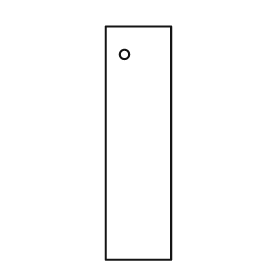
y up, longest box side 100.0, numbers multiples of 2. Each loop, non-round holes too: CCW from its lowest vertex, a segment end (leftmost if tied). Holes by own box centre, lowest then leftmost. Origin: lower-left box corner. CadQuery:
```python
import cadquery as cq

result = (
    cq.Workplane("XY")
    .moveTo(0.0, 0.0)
    .lineTo(28.0, 0.0)
    .lineTo(28.0, 100.0)
    .lineTo(0.0, 100.0)
    .close()
    .moveTo(8.0, 88.0)
    .circle(2.0)
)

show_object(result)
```